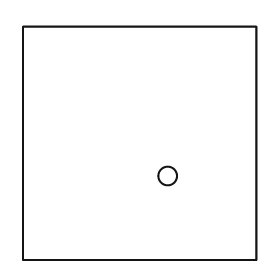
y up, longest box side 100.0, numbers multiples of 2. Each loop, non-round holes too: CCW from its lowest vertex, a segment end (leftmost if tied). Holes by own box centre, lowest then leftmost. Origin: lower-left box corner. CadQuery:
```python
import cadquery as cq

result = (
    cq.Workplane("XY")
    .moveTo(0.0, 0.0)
    .lineTo(100.0, 0.0)
    .lineTo(100.0, 100.0)
    .lineTo(0.0, 100.0)
    .close()
    .moveTo(62.0, 36.0)
    .circle(4.0)
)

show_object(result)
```